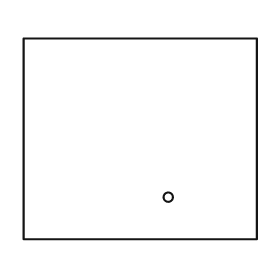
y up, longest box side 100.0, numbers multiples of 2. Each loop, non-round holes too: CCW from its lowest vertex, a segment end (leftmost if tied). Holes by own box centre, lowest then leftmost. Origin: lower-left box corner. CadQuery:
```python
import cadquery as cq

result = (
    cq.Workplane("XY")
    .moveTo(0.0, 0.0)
    .lineTo(100.0, 0.0)
    .lineTo(100.0, 86.0)
    .lineTo(0.0, 86.0)
    .close()
    .moveTo(62.0, 18.0)
    .circle(2.0)
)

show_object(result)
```